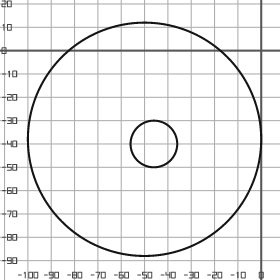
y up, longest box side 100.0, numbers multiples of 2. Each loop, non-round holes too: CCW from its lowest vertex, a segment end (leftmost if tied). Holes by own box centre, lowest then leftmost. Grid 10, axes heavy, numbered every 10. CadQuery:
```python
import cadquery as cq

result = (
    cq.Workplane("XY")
    .moveTo(-50.0, -38.0)
    .circle(50.0)
    .moveTo(-46.0, -40.0)
    .circle(10.0)
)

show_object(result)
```